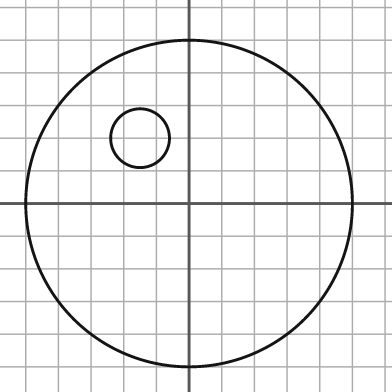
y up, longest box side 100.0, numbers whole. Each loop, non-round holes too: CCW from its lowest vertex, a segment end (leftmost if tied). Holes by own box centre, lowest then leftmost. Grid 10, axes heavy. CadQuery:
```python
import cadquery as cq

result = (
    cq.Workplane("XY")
    .moveTo(0.0, 0.0)
    .circle(50.0)
    .moveTo(-15.0, 20.0)
    .circle(9.0)
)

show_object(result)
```